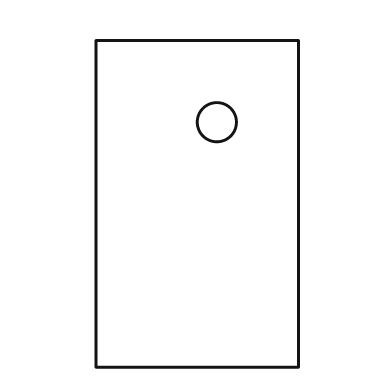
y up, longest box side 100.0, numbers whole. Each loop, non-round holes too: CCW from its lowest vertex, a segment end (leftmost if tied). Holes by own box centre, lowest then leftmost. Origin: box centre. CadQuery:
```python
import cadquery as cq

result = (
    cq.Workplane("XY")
    .moveTo(-31.0, -50.0)
    .lineTo(31.0, -50.0)
    .lineTo(31.0, 50.0)
    .lineTo(-31.0, 50.0)
    .close()
    .moveTo(6.0, 25.0)
    .circle(6.0)
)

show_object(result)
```